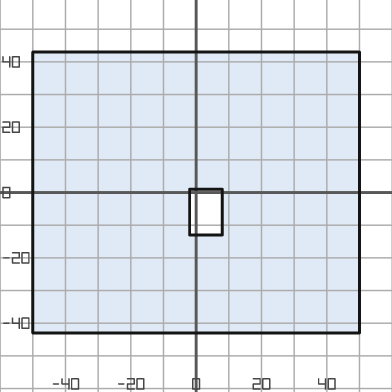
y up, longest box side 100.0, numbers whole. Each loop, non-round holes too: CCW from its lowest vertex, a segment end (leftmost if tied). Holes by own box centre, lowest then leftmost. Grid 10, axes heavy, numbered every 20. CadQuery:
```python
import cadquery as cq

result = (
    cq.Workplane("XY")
    .moveTo(-50.0, -43.0)
    .lineTo(50.0, -43.0)
    .lineTo(50.0, 43.0)
    .lineTo(-50.0, 43.0)
    .close()
    .moveTo(-2.0, -13.0)
    .lineTo(8.0, -13.0)
    .lineTo(8.0, 1.0)
    .lineTo(-2.0, 1.0)
    .close()
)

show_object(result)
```